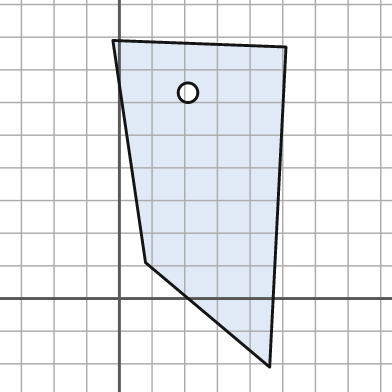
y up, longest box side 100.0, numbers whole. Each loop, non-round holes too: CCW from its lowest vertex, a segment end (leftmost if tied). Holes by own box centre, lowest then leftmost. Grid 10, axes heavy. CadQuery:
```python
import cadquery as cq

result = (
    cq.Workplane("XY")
    .moveTo(46.0, -21.0)
    .lineTo(51.0, 77.0)
    .lineTo(-2.0, 79.0)
    .lineTo(8.0, 11.0)
    .close()
    .moveTo(21.0, 63.0)
    .circle(3.0)
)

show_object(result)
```